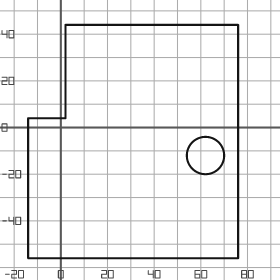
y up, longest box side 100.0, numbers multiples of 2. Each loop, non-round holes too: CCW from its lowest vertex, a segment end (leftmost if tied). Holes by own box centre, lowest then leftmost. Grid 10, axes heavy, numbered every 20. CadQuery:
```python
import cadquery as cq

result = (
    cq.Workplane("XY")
    .moveTo(-14.0, -56.0)
    .lineTo(76.0, -56.0)
    .lineTo(76.0, 44.0)
    .lineTo(2.0, 44.0)
    .lineTo(2.0, 4.0)
    .lineTo(-14.0, 4.0)
    .close()
    .moveTo(62.0, -12.0)
    .circle(8.0)
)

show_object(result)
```